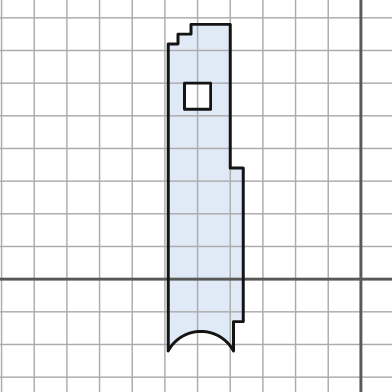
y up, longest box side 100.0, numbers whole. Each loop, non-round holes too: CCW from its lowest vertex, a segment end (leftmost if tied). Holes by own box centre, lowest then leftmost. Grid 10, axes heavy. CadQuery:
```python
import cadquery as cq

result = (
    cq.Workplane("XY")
    .moveTo(-59.0, -22.0)
    .threePointArc((-49.0, -16.0), (-39.0, -22.0))
    .lineTo(-39.0, -13.0)
    .lineTo(-36.0, -13.0)
    .lineTo(-36.0, 34.0)
    .lineTo(-40.0, 34.0)
    .lineTo(-40.0, 78.0)
    .lineTo(-52.0, 78.0)
    .lineTo(-52.0, 75.0)
    .lineTo(-56.0, 75.0)
    .lineTo(-56.0, 72.0)
    .lineTo(-59.0, 72.0)
    .close()
    .moveTo(-54.0, 52.0)
    .lineTo(-46.0, 52.0)
    .lineTo(-46.0, 60.0)
    .lineTo(-54.0, 60.0)
    .close()
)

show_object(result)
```